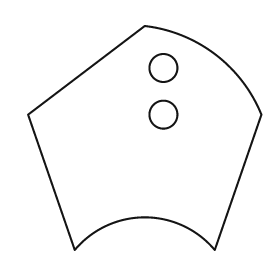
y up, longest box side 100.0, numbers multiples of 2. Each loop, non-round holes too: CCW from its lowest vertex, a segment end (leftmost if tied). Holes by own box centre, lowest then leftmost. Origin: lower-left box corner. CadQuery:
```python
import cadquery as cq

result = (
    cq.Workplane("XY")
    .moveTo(20.0, 0.0)
    .threePointArc((50.0, 14.0), (80.0, 0.0))
    .lineTo(100.0, 58.0)
    .threePointArc((80.0, 84.0), (50.0, 96.0))
    .lineTo(0.0, 58.0)
    .close()
    .moveTo(58.0, 58.0)
    .circle(6.0)
    .moveTo(58.0, 78.0)
    .circle(6.0)
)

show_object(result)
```